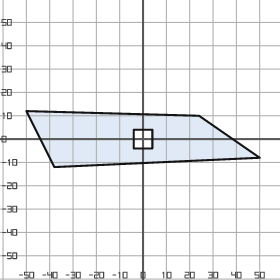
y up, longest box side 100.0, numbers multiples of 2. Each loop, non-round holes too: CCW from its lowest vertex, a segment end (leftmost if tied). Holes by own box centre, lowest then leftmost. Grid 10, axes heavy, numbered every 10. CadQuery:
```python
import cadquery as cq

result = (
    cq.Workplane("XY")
    .moveTo(-38.0, -12.0)
    .lineTo(50.0, -8.0)
    .lineTo(24.0, 10.0)
    .lineTo(-50.0, 12.0)
    .close()
    .moveTo(-4.0, -4.0)
    .lineTo(4.0, -4.0)
    .lineTo(4.0, 4.0)
    .lineTo(-4.0, 4.0)
    .close()
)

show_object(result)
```